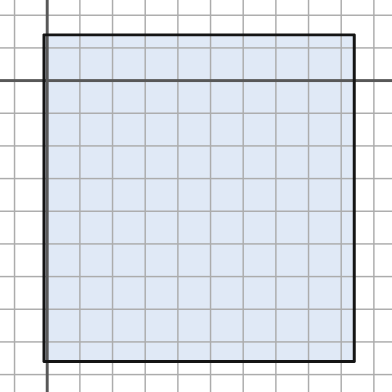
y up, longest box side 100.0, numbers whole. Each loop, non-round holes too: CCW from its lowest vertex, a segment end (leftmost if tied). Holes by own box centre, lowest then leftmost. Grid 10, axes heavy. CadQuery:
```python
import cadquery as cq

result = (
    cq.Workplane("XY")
    .moveTo(-1.0, -86.0)
    .lineTo(94.0, -86.0)
    .lineTo(94.0, 14.0)
    .lineTo(-1.0, 14.0)
    .close()
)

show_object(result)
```